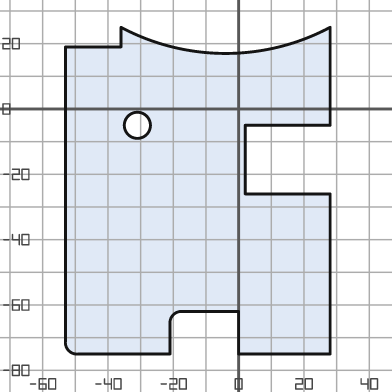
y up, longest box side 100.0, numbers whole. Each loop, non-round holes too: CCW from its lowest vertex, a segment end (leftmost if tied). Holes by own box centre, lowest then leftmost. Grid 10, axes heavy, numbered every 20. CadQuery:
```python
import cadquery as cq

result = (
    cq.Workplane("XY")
    .moveTo(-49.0, -75.0)
    .lineTo(-21.0, -75.0)
    .lineTo(-21.0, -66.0)
    .threePointArc((-20.0, -63.0), (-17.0, -62.0))
    .lineTo(0.0, -62.0)
    .lineTo(0.0, -75.0)
    .lineTo(28.0, -75.0)
    .lineTo(28.0, -26.0)
    .lineTo(2.0, -26.0)
    .lineTo(2.0, -5.0)
    .lineTo(28.0, -5.0)
    .lineTo(28.0, 25.0)
    .threePointArc((-4.0, 17.0), (-36.0, 25.0))
    .lineTo(-36.0, 19.0)
    .lineTo(-53.0, 19.0)
    .lineTo(-53.0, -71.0)
    .threePointArc((-52.0, -74.0), (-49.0, -75.0))
    .close()
    .moveTo(-31.0, -5.0)
    .circle(4.0)
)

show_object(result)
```